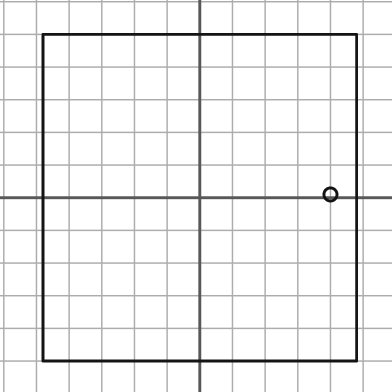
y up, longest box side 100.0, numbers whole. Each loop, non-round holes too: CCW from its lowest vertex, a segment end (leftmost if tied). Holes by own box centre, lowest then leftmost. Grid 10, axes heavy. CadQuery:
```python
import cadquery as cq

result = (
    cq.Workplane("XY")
    .moveTo(-48.0, -50.0)
    .lineTo(48.0, -50.0)
    .lineTo(48.0, 50.0)
    .lineTo(-48.0, 50.0)
    .close()
    .moveTo(40.0, 1.0)
    .circle(2.0)
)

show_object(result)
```